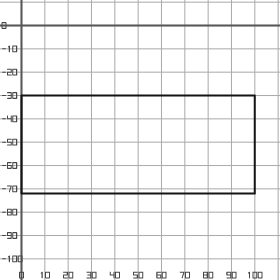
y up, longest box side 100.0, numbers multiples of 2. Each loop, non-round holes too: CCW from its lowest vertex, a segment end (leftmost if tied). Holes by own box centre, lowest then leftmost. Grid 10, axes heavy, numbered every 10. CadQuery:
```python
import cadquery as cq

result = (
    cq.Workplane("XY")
    .moveTo(0.0, -72.0)
    .lineTo(100.0, -72.0)
    .lineTo(100.0, -30.0)
    .lineTo(0.0, -30.0)
    .close()
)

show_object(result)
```